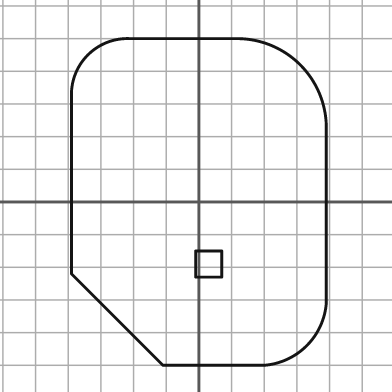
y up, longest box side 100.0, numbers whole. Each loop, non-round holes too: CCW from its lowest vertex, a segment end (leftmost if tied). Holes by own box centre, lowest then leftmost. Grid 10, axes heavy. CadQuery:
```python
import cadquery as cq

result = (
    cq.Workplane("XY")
    .moveTo(-11.0, -50.0)
    .lineTo(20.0, -50.0)
    .threePointArc((33.0, -44.0), (39.0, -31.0))
    .lineTo(39.0, 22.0)
    .threePointArc((31.0, 42.0), (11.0, 50.0))
    .lineTo(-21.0, 50.0)
    .threePointArc((-34.0, 45.0), (-39.0, 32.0))
    .lineTo(-39.0, -22.0)
    .close()
    .moveTo(-1.0, -23.0)
    .lineTo(7.0, -23.0)
    .lineTo(7.0, -15.0)
    .lineTo(-1.0, -15.0)
    .close()
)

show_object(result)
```